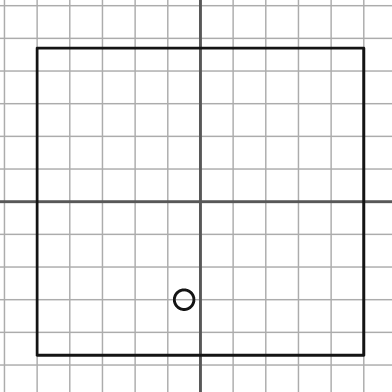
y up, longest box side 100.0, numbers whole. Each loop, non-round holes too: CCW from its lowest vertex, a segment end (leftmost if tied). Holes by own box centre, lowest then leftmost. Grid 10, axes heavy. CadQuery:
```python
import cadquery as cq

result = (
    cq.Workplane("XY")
    .moveTo(-50.0, -47.0)
    .lineTo(50.0, -47.0)
    .lineTo(50.0, 47.0)
    .lineTo(-50.0, 47.0)
    .close()
    .moveTo(-5.0, -30.0)
    .circle(3.0)
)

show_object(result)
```